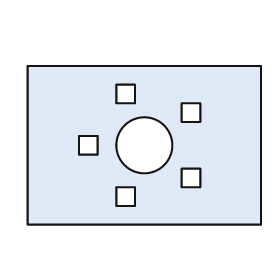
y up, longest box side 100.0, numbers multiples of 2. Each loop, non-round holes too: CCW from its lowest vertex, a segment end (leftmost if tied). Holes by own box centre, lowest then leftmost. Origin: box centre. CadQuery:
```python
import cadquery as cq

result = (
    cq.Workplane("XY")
    .moveTo(-50.0, -34.0)
    .lineTo(50.0, -34.0)
    .lineTo(50.0, 34.0)
    .lineTo(-50.0, 34.0)
    .close()
    .moveTo(-12.0, -26.0)
    .lineTo(-4.0, -26.0)
    .lineTo(-4.0, -18.0)
    .lineTo(-12.0, -18.0)
    .close()
    .moveTo(16.0, -18.0)
    .lineTo(24.0, -18.0)
    .lineTo(24.0, -10.0)
    .lineTo(16.0, -10.0)
    .close()
    .moveTo(-28.0, -4.0)
    .lineTo(-20.0, -4.0)
    .lineTo(-20.0, 4.0)
    .lineTo(-28.0, 4.0)
    .close()
    .moveTo(0.0, 0.0)
    .circle(12.0)
    .moveTo(16.0, 10.0)
    .lineTo(24.0, 10.0)
    .lineTo(24.0, 18.0)
    .lineTo(16.0, 18.0)
    .close()
    .moveTo(-12.0, 18.0)
    .lineTo(-4.0, 18.0)
    .lineTo(-4.0, 26.0)
    .lineTo(-12.0, 26.0)
    .close()
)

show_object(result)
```